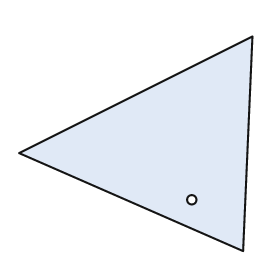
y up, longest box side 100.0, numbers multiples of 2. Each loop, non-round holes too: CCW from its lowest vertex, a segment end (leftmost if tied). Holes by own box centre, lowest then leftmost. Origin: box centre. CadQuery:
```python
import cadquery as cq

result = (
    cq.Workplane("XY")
    .moveTo(46.0, -46.0)
    .lineTo(50.0, 46.0)
    .lineTo(-50.0, -4.0)
    .close()
    .moveTo(24.0, -24.0)
    .circle(2.0)
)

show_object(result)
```